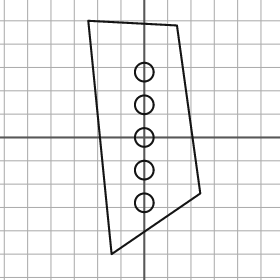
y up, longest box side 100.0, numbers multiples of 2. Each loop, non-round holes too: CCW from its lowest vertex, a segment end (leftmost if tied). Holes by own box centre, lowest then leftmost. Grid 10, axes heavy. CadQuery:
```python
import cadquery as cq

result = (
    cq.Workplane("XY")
    .moveTo(-14.0, -50.0)
    .lineTo(24.0, -24.0)
    .lineTo(14.0, 48.0)
    .lineTo(-24.0, 50.0)
    .close()
    .moveTo(0.0, -28.0)
    .circle(4.0)
    .moveTo(0.0, -14.0)
    .circle(4.0)
    .moveTo(0.0, 0.0)
    .circle(4.0)
    .moveTo(0.0, 14.0)
    .circle(4.0)
    .moveTo(0.0, 28.0)
    .circle(4.0)
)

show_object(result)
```